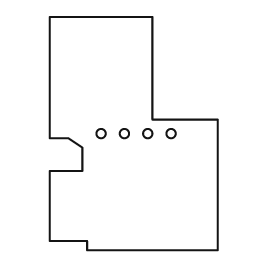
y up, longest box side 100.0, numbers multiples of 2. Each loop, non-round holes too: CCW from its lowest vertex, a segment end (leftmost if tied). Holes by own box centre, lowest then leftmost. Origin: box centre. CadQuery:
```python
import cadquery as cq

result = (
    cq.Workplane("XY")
    .moveTo(-20.0, -50.0)
    .lineTo(36.0, -50.0)
    .lineTo(36.0, 6.0)
    .lineTo(8.0, 6.0)
    .lineTo(8.0, 50.0)
    .lineTo(-36.0, 50.0)
    .lineTo(-36.0, -2.0)
    .lineTo(-28.0, -2.0)
    .lineTo(-22.0, -6.0)
    .lineTo(-22.0, -16.0)
    .lineTo(-36.0, -16.0)
    .lineTo(-36.0, -46.0)
    .lineTo(-20.0, -46.0)
    .close()
    .moveTo(-14.0, 0.0)
    .circle(2.0)
    .moveTo(-4.0, 0.0)
    .circle(2.0)
    .moveTo(6.0, 0.0)
    .circle(2.0)
    .moveTo(16.0, 0.0)
    .circle(2.0)
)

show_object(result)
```